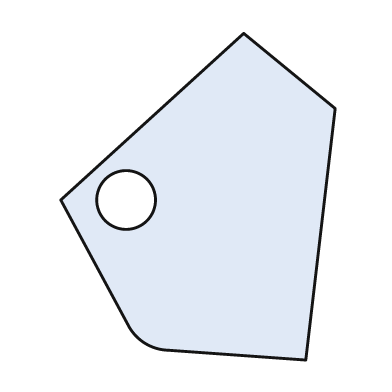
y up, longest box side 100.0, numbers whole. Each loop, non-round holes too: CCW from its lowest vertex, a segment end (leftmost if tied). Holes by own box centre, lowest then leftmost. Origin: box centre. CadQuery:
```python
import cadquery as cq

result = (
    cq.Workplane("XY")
    .moveTo(33.0, -50.0)
    .lineTo(42.0, 27.0)
    .lineTo(14.0, 50.0)
    .lineTo(-42.0, -1.0)
    .lineTo(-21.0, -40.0)
    .threePointArc((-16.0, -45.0), (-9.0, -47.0))
    .close()
    .moveTo(-22.0, -1.0)
    .circle(9.0)
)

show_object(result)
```